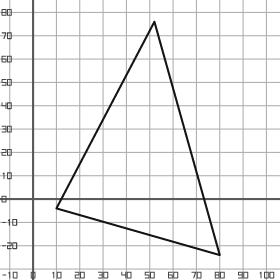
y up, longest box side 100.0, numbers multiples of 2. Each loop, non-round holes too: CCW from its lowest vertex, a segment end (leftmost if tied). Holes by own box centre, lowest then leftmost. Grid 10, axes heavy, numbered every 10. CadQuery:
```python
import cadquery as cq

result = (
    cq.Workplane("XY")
    .moveTo(80.0, -24.0)
    .lineTo(52.0, 76.0)
    .lineTo(10.0, -4.0)
    .close()
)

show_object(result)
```